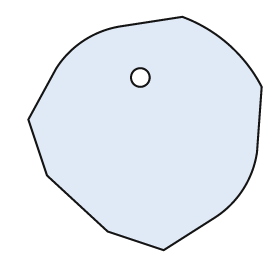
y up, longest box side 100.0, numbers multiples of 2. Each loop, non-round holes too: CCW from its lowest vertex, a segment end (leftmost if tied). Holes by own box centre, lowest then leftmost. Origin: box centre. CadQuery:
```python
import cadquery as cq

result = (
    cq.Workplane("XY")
    .moveTo(8.0, -50.0)
    .lineTo(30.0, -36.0)
    .threePointArc((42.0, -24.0), (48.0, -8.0))
    .lineTo(50.0, 20.0)
    .threePointArc((36.0, 38.0), (16.0, 50.0))
    .lineTo(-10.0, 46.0)
    .threePointArc((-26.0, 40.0), (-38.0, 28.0))
    .lineTo(-50.0, 6.0)
    .lineTo(-42.0, -18.0)
    .lineTo(-16.0, -42.0)
    .close()
    .moveTo(-2.0, 24.0)
    .circle(4.0)
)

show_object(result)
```